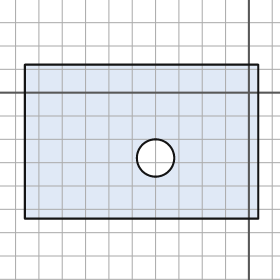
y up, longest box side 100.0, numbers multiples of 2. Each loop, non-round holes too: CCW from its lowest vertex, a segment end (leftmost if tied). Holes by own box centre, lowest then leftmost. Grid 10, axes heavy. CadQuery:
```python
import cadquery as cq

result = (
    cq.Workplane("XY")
    .moveTo(-96.0, -54.0)
    .lineTo(4.0, -54.0)
    .lineTo(4.0, 12.0)
    .lineTo(-96.0, 12.0)
    .close()
    .moveTo(-40.0, -28.0)
    .circle(8.0)
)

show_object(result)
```